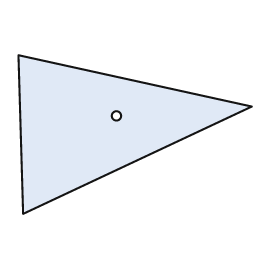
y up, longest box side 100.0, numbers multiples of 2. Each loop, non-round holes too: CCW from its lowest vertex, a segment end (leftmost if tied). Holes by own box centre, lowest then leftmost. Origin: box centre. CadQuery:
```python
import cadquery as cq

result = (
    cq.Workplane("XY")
    .moveTo(-48.0, -34.0)
    .lineTo(50.0, 12.0)
    .lineTo(-50.0, 34.0)
    .close()
    .moveTo(-8.0, 8.0)
    .circle(2.0)
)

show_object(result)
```